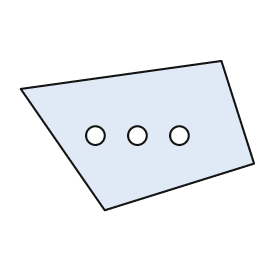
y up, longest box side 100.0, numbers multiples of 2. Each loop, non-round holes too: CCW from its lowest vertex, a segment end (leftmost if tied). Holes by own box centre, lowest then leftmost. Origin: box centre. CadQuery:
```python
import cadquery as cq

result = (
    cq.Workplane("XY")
    .moveTo(-14.0, -32.0)
    .lineTo(50.0, -12.0)
    .lineTo(36.0, 32.0)
    .lineTo(-50.0, 20.0)
    .close()
    .moveTo(-18.0, 0.0)
    .circle(4.0)
    .moveTo(0.0, 0.0)
    .circle(4.0)
    .moveTo(18.0, 0.0)
    .circle(4.0)
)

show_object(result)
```